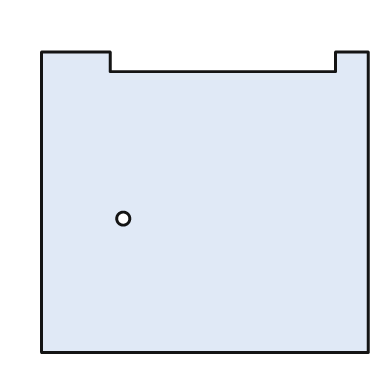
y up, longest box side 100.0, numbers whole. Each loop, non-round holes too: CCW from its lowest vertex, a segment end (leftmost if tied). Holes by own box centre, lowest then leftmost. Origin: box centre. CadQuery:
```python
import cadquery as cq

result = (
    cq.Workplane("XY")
    .moveTo(-50.0, -46.0)
    .lineTo(50.0, -46.0)
    .lineTo(50.0, 46.0)
    .lineTo(40.0, 46.0)
    .lineTo(40.0, 40.0)
    .lineTo(-29.0, 40.0)
    .lineTo(-29.0, 46.0)
    .lineTo(-50.0, 46.0)
    .close()
    .moveTo(-25.0, -5.0)
    .circle(2.0)
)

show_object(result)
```